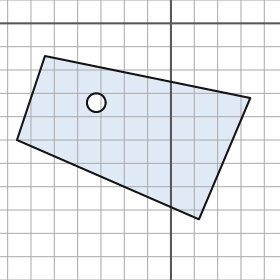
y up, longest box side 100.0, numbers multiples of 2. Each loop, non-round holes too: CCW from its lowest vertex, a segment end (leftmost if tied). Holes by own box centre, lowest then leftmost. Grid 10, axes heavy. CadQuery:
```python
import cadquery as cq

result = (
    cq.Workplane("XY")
    .moveTo(12.0, -84.0)
    .lineTo(34.0, -32.0)
    .lineTo(-54.0, -14.0)
    .lineTo(-66.0, -50.0)
    .close()
    .moveTo(-32.0, -34.0)
    .circle(4.0)
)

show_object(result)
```